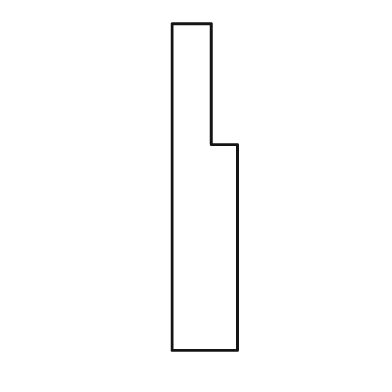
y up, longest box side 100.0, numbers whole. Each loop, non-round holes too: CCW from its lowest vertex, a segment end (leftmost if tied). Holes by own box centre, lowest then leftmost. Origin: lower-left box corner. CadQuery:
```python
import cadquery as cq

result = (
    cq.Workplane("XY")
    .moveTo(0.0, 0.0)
    .lineTo(20.0, 0.0)
    .lineTo(20.0, 63.0)
    .lineTo(12.0, 63.0)
    .lineTo(12.0, 100.0)
    .lineTo(0.0, 100.0)
    .close()
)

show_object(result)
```